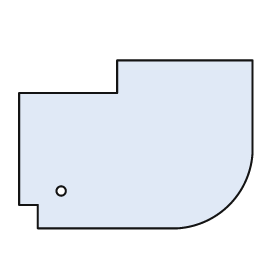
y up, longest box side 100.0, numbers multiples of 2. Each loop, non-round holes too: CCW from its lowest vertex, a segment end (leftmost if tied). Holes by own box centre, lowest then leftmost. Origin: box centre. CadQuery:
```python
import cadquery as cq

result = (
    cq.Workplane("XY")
    .moveTo(-42.0, -36.0)
    .lineTo(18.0, -36.0)
    .threePointArc((40.0, -26.0), (50.0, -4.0))
    .lineTo(50.0, 36.0)
    .lineTo(-8.0, 36.0)
    .lineTo(-8.0, 22.0)
    .lineTo(-50.0, 22.0)
    .lineTo(-50.0, -26.0)
    .lineTo(-42.0, -26.0)
    .close()
    .moveTo(-32.0, -20.0)
    .circle(2.0)
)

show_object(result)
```